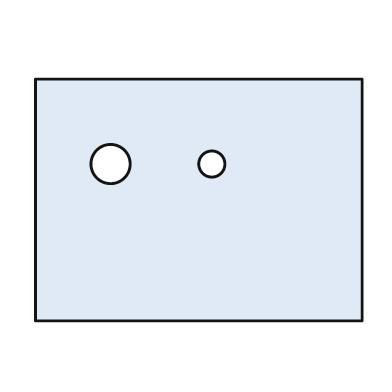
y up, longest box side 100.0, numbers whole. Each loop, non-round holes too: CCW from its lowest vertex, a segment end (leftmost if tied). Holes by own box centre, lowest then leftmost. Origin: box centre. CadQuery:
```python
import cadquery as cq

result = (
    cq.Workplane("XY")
    .moveTo(-50.0, -37.0)
    .lineTo(50.0, -37.0)
    .lineTo(50.0, 37.0)
    .lineTo(-50.0, 37.0)
    .close()
    .moveTo(-27.0, 11.0)
    .circle(6.0)
    .moveTo(4.0, 11.0)
    .circle(4.0)
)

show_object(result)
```